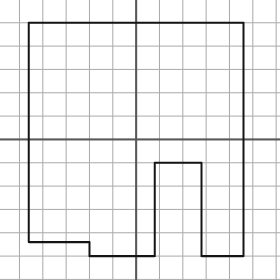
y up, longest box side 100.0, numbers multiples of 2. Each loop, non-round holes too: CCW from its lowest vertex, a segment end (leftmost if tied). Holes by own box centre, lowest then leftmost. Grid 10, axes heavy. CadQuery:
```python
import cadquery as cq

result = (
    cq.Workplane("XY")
    .moveTo(-20.0, -50.0)
    .lineTo(8.0, -50.0)
    .lineTo(8.0, -10.0)
    .lineTo(28.0, -10.0)
    .lineTo(28.0, -50.0)
    .lineTo(46.0, -50.0)
    .lineTo(46.0, 50.0)
    .lineTo(-46.0, 50.0)
    .lineTo(-46.0, -44.0)
    .lineTo(-20.0, -44.0)
    .close()
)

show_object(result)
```